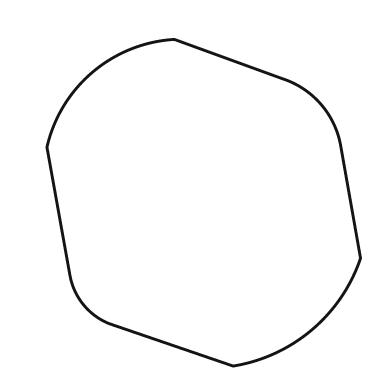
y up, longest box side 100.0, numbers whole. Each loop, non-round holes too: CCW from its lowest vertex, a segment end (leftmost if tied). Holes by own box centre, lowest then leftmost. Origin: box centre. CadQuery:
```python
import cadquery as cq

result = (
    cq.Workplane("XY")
    .moveTo(9.0, -50.0)
    .threePointArc((33.0, -39.0), (48.0, -17.0))
    .lineTo(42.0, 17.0)
    .threePointArc((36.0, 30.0), (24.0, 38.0))
    .lineTo(-9.0, 50.0)
    .threePointArc((-34.0, 40.0), (-48.0, 17.0))
    .lineTo(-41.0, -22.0)
    .threePointArc((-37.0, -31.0), (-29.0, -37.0))
    .close()
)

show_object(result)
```